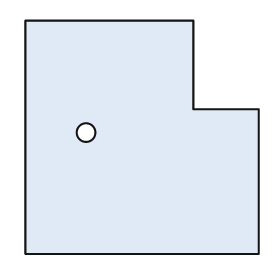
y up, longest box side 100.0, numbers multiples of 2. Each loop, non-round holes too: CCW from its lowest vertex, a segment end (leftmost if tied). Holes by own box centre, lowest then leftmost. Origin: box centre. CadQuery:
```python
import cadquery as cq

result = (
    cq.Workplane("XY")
    .moveTo(-50.0, -50.0)
    .lineTo(50.0, -50.0)
    .lineTo(50.0, 12.0)
    .lineTo(22.0, 12.0)
    .lineTo(22.0, 50.0)
    .lineTo(-50.0, 50.0)
    .close()
    .moveTo(-24.0, 2.0)
    .circle(4.0)
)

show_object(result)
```